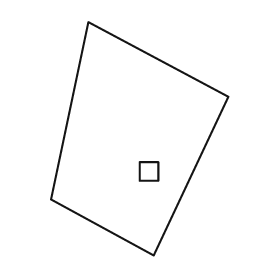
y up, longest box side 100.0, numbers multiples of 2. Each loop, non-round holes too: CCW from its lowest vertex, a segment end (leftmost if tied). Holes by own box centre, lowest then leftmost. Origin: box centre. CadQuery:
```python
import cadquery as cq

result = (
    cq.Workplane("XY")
    .moveTo(6.0, -50.0)
    .lineTo(38.0, 18.0)
    .lineTo(-22.0, 50.0)
    .lineTo(-38.0, -26.0)
    .close()
    .moveTo(0.0, -18.0)
    .lineTo(8.0, -18.0)
    .lineTo(8.0, -10.0)
    .lineTo(0.0, -10.0)
    .close()
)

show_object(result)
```